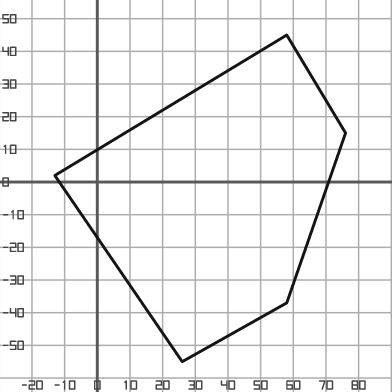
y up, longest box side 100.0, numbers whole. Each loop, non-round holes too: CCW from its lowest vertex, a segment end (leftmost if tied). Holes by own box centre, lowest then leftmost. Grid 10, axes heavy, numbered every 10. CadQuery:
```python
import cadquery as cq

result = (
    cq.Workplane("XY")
    .moveTo(26.0, -55.0)
    .lineTo(58.0, -37.0)
    .lineTo(76.0, 15.0)
    .lineTo(58.0, 45.0)
    .lineTo(-13.0, 2.0)
    .close()
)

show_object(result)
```